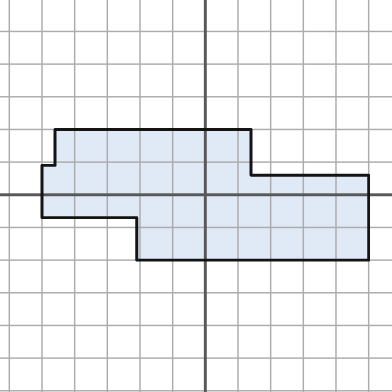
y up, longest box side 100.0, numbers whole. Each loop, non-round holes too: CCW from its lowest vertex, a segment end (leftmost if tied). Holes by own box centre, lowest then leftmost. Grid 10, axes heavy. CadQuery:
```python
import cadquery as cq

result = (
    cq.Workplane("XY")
    .moveTo(-21.0, -20.0)
    .lineTo(50.0, -20.0)
    .lineTo(50.0, 6.0)
    .lineTo(14.0, 6.0)
    .lineTo(14.0, 20.0)
    .lineTo(-46.0, 20.0)
    .lineTo(-46.0, 9.0)
    .lineTo(-50.0, 9.0)
    .lineTo(-50.0, -7.0)
    .lineTo(-21.0, -7.0)
    .close()
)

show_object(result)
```